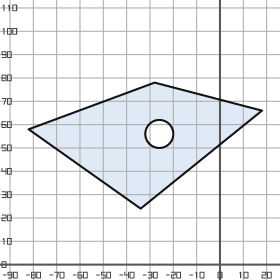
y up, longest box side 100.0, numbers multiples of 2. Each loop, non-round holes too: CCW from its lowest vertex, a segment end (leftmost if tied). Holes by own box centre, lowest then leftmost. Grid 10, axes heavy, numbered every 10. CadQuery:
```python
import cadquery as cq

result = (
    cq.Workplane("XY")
    .moveTo(-34.0, 24.0)
    .lineTo(18.0, 66.0)
    .lineTo(-28.0, 78.0)
    .lineTo(-82.0, 58.0)
    .close()
    .moveTo(-26.0, 56.0)
    .circle(6.0)
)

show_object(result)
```